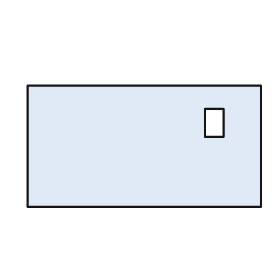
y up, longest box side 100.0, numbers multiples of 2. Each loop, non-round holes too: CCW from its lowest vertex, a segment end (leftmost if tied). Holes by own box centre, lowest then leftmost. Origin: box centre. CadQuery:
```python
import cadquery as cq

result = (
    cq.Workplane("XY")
    .moveTo(-50.0, -26.0)
    .lineTo(50.0, -26.0)
    .lineTo(50.0, 26.0)
    .lineTo(-50.0, 26.0)
    .close()
    .moveTo(26.0, 4.0)
    .lineTo(34.0, 4.0)
    .lineTo(34.0, 16.0)
    .lineTo(26.0, 16.0)
    .close()
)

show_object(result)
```